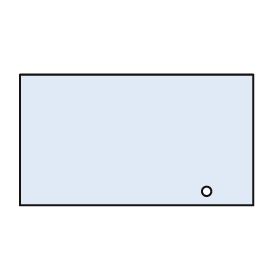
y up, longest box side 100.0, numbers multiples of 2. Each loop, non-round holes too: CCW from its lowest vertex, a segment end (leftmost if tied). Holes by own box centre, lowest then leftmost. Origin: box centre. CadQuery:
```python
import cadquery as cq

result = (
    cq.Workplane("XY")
    .moveTo(-50.0, -28.0)
    .lineTo(50.0, -28.0)
    .lineTo(50.0, 28.0)
    .lineTo(-50.0, 28.0)
    .close()
    .moveTo(30.0, -22.0)
    .circle(2.0)
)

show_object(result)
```